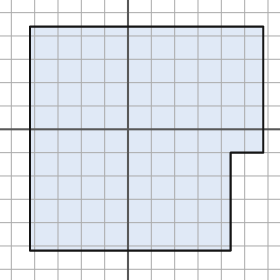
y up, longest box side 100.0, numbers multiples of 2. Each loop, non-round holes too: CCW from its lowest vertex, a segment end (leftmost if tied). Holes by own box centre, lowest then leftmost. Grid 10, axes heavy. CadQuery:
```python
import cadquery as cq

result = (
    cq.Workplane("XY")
    .moveTo(-42.0, -52.0)
    .lineTo(44.0, -52.0)
    .lineTo(44.0, -10.0)
    .lineTo(58.0, -10.0)
    .lineTo(58.0, 44.0)
    .lineTo(-42.0, 44.0)
    .close()
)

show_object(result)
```